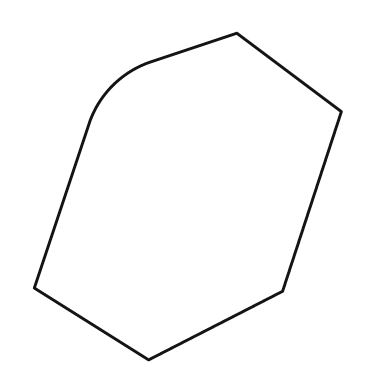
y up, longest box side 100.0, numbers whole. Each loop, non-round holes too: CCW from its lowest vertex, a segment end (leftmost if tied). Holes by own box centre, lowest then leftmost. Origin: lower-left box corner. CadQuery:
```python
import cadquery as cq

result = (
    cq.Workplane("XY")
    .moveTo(35.0, 0.0)
    .lineTo(76.0, 21.0)
    .lineTo(94.0, 76.0)
    .lineTo(62.0, 100.0)
    .lineTo(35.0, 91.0)
    .threePointArc((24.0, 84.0), (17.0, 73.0))
    .lineTo(0.0, 22.0)
    .close()
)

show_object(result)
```